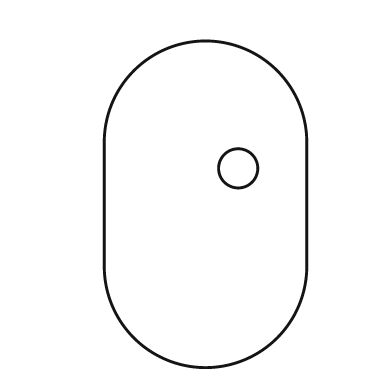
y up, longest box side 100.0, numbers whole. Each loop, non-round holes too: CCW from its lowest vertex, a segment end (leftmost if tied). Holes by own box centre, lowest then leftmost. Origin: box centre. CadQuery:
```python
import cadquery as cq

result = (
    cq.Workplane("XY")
    .moveTo(-31.0, -19.0)
    .threePointArc((0.0, -50.0), (31.0, -19.0))
    .lineTo(31.0, 19.0)
    .threePointArc((0.0, 50.0), (-31.0, 19.0))
    .close()
    .moveTo(10.0, 11.0)
    .circle(6.0)
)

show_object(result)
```